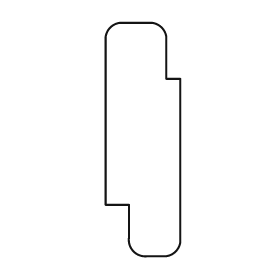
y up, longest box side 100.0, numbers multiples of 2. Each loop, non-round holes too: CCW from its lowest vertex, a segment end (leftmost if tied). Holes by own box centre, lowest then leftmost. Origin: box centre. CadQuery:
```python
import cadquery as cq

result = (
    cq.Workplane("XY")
    .moveTo(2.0, -50.0)
    .lineTo(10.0, -50.0)
    .threePointArc((14.0, -48.0), (16.0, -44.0))
    .lineTo(16.0, 26.0)
    .lineTo(10.0, 26.0)
    .lineTo(10.0, 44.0)
    .threePointArc((8.0, 48.0), (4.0, 50.0))
    .lineTo(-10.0, 50.0)
    .threePointArc((-14.0, 48.0), (-16.0, 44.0))
    .lineTo(-16.0, -28.0)
    .lineTo(-6.0, -28.0)
    .lineTo(-6.0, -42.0)
    .threePointArc((-4.0, -48.0), (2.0, -50.0))
    .close()
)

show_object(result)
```